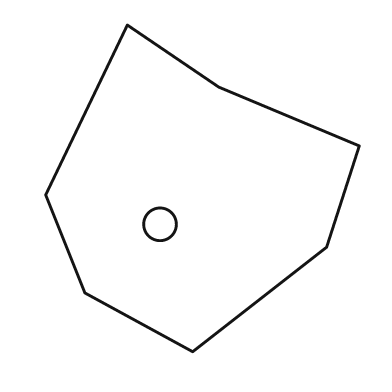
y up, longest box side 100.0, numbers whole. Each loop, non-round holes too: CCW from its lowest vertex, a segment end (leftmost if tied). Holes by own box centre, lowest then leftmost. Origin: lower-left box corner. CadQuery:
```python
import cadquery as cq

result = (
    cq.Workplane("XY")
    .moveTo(45.0, 0.0)
    .lineTo(86.0, 32.0)
    .lineTo(96.0, 63.0)
    .lineTo(53.0, 81.0)
    .lineTo(25.0, 100.0)
    .lineTo(0.0, 48.0)
    .lineTo(12.0, 18.0)
    .close()
    .moveTo(35.0, 39.0)
    .circle(5.0)
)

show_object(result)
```